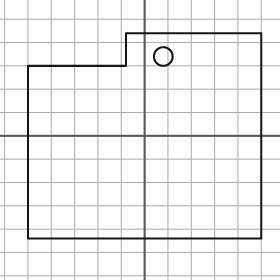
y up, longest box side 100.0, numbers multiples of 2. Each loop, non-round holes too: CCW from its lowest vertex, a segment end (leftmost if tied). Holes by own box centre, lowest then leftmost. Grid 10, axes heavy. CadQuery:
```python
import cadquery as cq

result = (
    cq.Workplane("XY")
    .moveTo(-50.0, -44.0)
    .lineTo(50.0, -44.0)
    .lineTo(50.0, 44.0)
    .lineTo(-8.0, 44.0)
    .lineTo(-8.0, 30.0)
    .lineTo(-50.0, 30.0)
    .close()
    .moveTo(8.0, 34.0)
    .circle(4.0)
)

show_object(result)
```